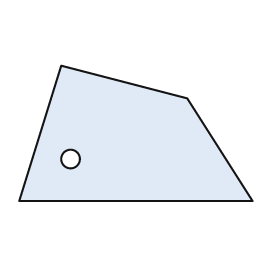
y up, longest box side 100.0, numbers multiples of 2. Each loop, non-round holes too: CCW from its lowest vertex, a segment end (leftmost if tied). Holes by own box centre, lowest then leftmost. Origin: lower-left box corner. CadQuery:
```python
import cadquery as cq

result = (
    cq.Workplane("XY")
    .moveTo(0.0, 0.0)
    .lineTo(100.0, 0.0)
    .lineTo(72.0, 44.0)
    .lineTo(18.0, 58.0)
    .close()
    .moveTo(22.0, 18.0)
    .circle(4.0)
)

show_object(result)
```